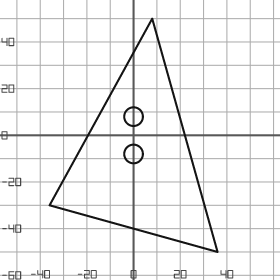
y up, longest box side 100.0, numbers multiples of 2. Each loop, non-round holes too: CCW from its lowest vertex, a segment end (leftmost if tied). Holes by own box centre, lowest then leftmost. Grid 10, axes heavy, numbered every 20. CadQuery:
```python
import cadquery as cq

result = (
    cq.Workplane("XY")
    .moveTo(36.0, -50.0)
    .lineTo(8.0, 50.0)
    .lineTo(-36.0, -30.0)
    .close()
    .moveTo(0.0, -8.0)
    .circle(4.0)
    .moveTo(0.0, 8.0)
    .circle(4.0)
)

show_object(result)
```